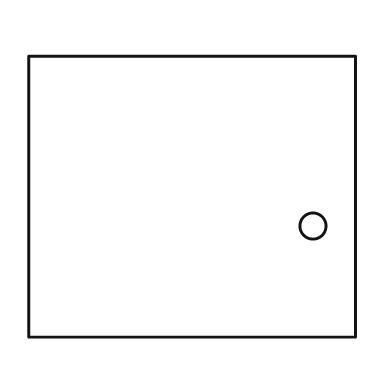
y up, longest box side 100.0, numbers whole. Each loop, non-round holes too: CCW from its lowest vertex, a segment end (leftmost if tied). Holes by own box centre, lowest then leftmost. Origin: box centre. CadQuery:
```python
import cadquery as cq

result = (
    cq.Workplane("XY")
    .moveTo(-50.0, -43.0)
    .lineTo(50.0, -43.0)
    .lineTo(50.0, 43.0)
    .lineTo(-50.0, 43.0)
    .close()
    .moveTo(37.0, -9.0)
    .circle(4.0)
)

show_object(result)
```